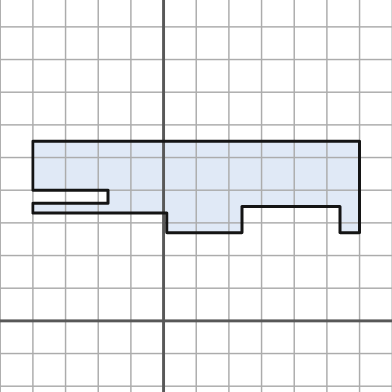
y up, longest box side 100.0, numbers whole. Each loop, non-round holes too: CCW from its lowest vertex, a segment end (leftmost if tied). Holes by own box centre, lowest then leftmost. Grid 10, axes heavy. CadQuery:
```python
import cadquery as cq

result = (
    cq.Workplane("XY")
    .moveTo(1.0, 27.0)
    .lineTo(24.0, 27.0)
    .lineTo(24.0, 35.0)
    .lineTo(54.0, 35.0)
    .lineTo(54.0, 27.0)
    .lineTo(60.0, 27.0)
    .lineTo(60.0, 55.0)
    .lineTo(-40.0, 55.0)
    .lineTo(-40.0, 40.0)
    .lineTo(-17.0, 40.0)
    .lineTo(-17.0, 36.0)
    .lineTo(-40.0, 36.0)
    .lineTo(-40.0, 33.0)
    .lineTo(1.0, 33.0)
    .close()
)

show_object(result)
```